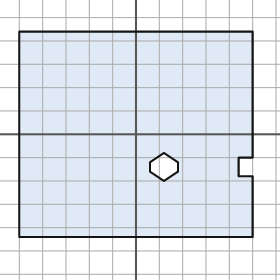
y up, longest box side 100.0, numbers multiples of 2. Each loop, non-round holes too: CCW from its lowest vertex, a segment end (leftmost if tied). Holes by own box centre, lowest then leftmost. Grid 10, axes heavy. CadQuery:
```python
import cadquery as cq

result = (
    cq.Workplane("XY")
    .moveTo(-50.0, -44.0)
    .lineTo(50.0, -44.0)
    .lineTo(50.0, -18.0)
    .lineTo(44.0, -18.0)
    .lineTo(44.0, -10.0)
    .lineTo(50.0, -10.0)
    .lineTo(50.0, 44.0)
    .lineTo(-50.0, 44.0)
    .close()
    .moveTo(12.0, -20.0)
    .lineTo(18.0, -16.0)
    .lineTo(18.0, -12.0)
    .lineTo(12.0, -8.0)
    .lineTo(6.0, -12.0)
    .lineTo(6.0, -16.0)
    .close()
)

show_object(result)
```